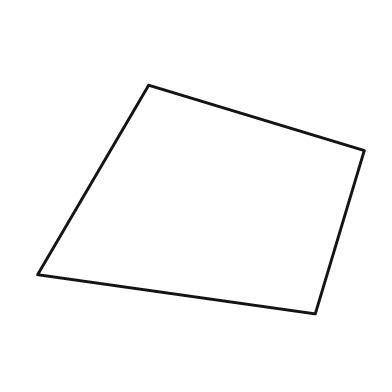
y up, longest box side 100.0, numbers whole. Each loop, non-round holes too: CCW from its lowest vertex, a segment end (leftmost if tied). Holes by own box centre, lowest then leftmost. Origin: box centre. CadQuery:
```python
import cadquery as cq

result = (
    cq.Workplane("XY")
    .moveTo(35.0, -35.0)
    .lineTo(50.0, 15.0)
    .lineTo(-16.0, 35.0)
    .lineTo(-50.0, -23.0)
    .close()
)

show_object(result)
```